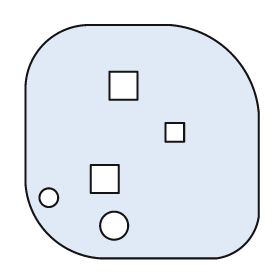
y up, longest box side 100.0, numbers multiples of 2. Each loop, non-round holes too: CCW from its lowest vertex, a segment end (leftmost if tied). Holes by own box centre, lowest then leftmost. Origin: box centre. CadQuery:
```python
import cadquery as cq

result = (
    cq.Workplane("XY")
    .moveTo(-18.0, -50.0)
    .lineTo(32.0, -50.0)
    .threePointArc((44.0, -44.0), (50.0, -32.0))
    .lineTo(50.0, 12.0)
    .threePointArc((38.0, 38.0), (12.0, 50.0))
    .lineTo(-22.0, 50.0)
    .threePointArc((-42.0, 42.0), (-50.0, 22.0))
    .lineTo(-50.0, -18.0)
    .threePointArc((-40.0, -40.0), (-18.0, -50.0))
    .close()
    .moveTo(-12.0, -36.0)
    .circle(6.0)
    .moveTo(-40.0, -24.0)
    .circle(4.0)
    .moveTo(-22.0, -22.0)
    .lineTo(-10.0, -22.0)
    .lineTo(-10.0, -10.0)
    .lineTo(-22.0, -10.0)
    .close()
    .moveTo(10.0, 0.0)
    .lineTo(18.0, 0.0)
    .lineTo(18.0, 8.0)
    .lineTo(10.0, 8.0)
    .close()
    .moveTo(-14.0, 18.0)
    .lineTo(-2.0, 18.0)
    .lineTo(-2.0, 30.0)
    .lineTo(-14.0, 30.0)
    .close()
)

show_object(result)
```